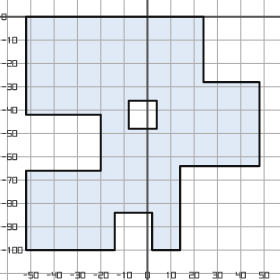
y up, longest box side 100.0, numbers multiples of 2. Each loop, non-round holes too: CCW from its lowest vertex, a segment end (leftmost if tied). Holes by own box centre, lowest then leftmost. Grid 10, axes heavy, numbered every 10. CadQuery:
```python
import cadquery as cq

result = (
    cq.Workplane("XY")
    .moveTo(-52.0, -100.0)
    .lineTo(-14.0, -100.0)
    .lineTo(-14.0, -84.0)
    .lineTo(2.0, -84.0)
    .lineTo(2.0, -100.0)
    .lineTo(14.0, -100.0)
    .lineTo(14.0, -64.0)
    .lineTo(48.0, -64.0)
    .lineTo(48.0, -28.0)
    .lineTo(24.0, -28.0)
    .lineTo(24.0, 0.0)
    .lineTo(-52.0, 0.0)
    .lineTo(-52.0, -42.0)
    .lineTo(-20.0, -42.0)
    .lineTo(-20.0, -66.0)
    .lineTo(-52.0, -66.0)
    .close()
    .moveTo(-8.0, -48.0)
    .lineTo(4.0, -48.0)
    .lineTo(4.0, -36.0)
    .lineTo(-8.0, -36.0)
    .close()
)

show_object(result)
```